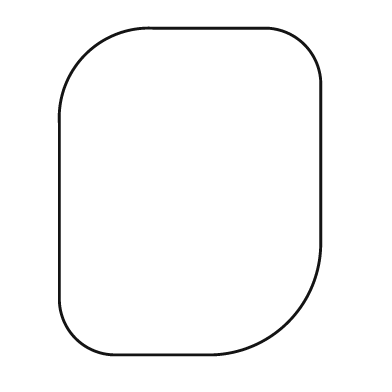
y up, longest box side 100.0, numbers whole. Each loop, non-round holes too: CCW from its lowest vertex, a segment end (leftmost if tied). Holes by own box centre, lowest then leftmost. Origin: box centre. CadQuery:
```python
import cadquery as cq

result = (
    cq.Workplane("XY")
    .moveTo(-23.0, -50.0)
    .lineTo(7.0, -50.0)
    .threePointArc((30.0, -40.0), (40.0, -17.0))
    .lineTo(40.0, 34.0)
    .threePointArc((35.0, 45.0), (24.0, 50.0))
    .lineTo(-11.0, 50.0)
    .threePointArc((-32.0, 42.0), (-40.0, 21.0))
    .lineTo(-40.0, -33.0)
    .threePointArc((-35.0, -45.0), (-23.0, -50.0))
    .close()
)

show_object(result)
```